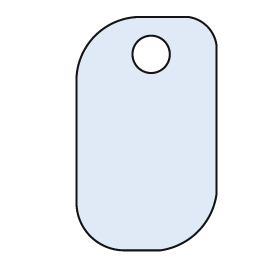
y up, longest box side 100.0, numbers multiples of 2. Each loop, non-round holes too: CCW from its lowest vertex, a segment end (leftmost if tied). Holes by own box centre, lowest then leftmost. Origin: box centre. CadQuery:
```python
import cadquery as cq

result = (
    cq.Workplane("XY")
    .moveTo(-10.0, -50.0)
    .lineTo(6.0, -50.0)
    .threePointArc((22.0, -42.0), (30.0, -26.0))
    .lineTo(30.0, 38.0)
    .threePointArc((26.0, 46.0), (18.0, 50.0))
    .lineTo(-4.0, 50.0)
    .threePointArc((-22.0, 42.0), (-30.0, 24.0))
    .lineTo(-30.0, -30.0)
    .threePointArc((-24.0, -44.0), (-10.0, -50.0))
    .close()
    .moveTo(2.0, 34.0)
    .circle(8.0)
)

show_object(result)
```